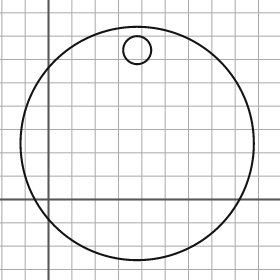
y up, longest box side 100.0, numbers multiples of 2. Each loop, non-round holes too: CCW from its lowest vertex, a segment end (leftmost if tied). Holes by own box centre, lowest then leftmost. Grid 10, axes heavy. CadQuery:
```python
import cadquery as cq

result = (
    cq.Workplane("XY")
    .moveTo(38.0, 24.0)
    .circle(50.0)
    .moveTo(38.0, 64.0)
    .circle(6.0)
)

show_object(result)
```